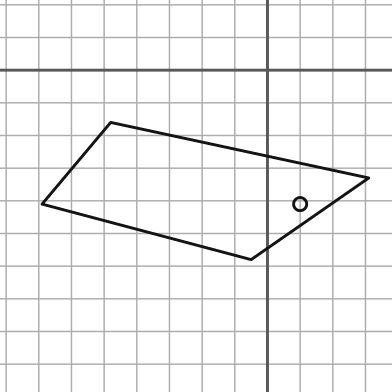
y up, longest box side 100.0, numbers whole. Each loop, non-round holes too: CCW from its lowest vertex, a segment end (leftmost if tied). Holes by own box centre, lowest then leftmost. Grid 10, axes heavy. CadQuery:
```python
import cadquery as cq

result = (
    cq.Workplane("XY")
    .moveTo(-5.0, -58.0)
    .lineTo(31.0, -33.0)
    .lineTo(-48.0, -16.0)
    .lineTo(-69.0, -41.0)
    .close()
    .moveTo(10.0, -41.0)
    .circle(2.0)
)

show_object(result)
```